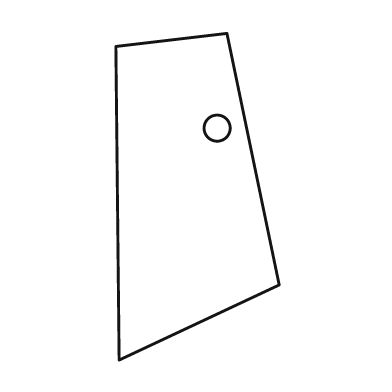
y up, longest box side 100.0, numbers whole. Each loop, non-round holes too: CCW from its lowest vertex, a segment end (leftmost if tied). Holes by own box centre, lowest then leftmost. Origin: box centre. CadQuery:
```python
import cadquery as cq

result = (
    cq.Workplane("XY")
    .moveTo(-24.0, -50.0)
    .lineTo(25.0, -27.0)
    .lineTo(9.0, 50.0)
    .lineTo(-25.0, 46.0)
    .close()
    .moveTo(6.0, 21.0)
    .circle(4.0)
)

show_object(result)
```